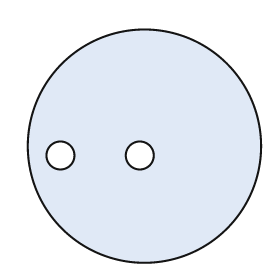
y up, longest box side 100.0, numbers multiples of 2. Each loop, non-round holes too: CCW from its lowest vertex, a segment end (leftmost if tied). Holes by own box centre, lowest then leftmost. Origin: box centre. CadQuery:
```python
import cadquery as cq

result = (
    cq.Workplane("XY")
    .moveTo(0.0, 0.0)
    .circle(50.0)
    .moveTo(-36.0, -4.0)
    .circle(6.0)
    .moveTo(-2.0, -4.0)
    .circle(6.0)
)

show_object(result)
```